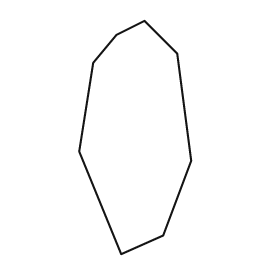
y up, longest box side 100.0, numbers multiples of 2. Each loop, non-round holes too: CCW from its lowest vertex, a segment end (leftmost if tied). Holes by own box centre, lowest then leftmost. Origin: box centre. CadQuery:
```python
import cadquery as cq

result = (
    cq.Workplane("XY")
    .moveTo(-6.0, -50.0)
    .lineTo(12.0, -42.0)
    .lineTo(24.0, -10.0)
    .lineTo(18.0, 36.0)
    .lineTo(4.0, 50.0)
    .lineTo(-8.0, 44.0)
    .lineTo(-18.0, 32.0)
    .lineTo(-24.0, -6.0)
    .close()
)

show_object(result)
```